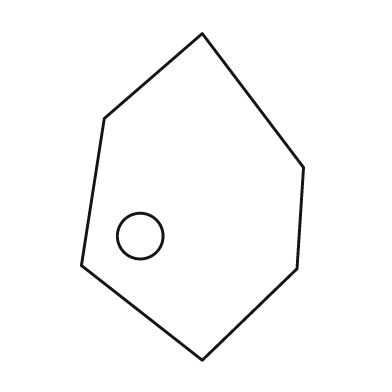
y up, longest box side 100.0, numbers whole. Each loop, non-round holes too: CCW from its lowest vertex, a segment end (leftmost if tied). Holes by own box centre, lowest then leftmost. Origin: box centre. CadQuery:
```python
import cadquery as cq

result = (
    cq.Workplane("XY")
    .moveTo(3.0, -50.0)
    .lineTo(32.0, -22.0)
    .lineTo(34.0, 9.0)
    .lineTo(3.0, 50.0)
    .lineTo(-27.0, 24.0)
    .lineTo(-34.0, -21.0)
    .close()
    .moveTo(-16.0, -12.0)
    .circle(7.0)
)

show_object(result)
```